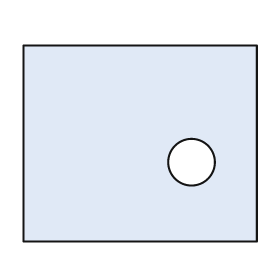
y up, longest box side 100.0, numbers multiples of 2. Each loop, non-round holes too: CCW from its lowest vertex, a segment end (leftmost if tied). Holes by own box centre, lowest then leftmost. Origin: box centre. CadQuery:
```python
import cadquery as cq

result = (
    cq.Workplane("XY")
    .moveTo(-50.0, -42.0)
    .lineTo(50.0, -42.0)
    .lineTo(50.0, 42.0)
    .lineTo(-50.0, 42.0)
    .close()
    .moveTo(22.0, -8.0)
    .circle(10.0)
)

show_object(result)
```